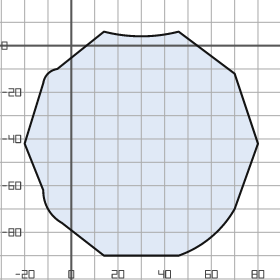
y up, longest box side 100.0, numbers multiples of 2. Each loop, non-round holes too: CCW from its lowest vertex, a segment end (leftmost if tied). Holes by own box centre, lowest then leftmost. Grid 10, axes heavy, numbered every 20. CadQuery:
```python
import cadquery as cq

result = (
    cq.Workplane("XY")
    .moveTo(14.0, -90.0)
    .lineTo(46.0, -90.0)
    .threePointArc((60.0, -82.0), (70.0, -70.0))
    .lineTo(80.0, -42.0)
    .lineTo(70.0, -12.0)
    .lineTo(46.0, 6.0)
    .threePointArc((30.0, 4.0), (14.0, 6.0))
    .lineTo(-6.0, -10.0)
    .threePointArc((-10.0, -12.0), (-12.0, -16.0))
    .lineTo(-20.0, -42.0)
    .lineTo(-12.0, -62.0)
    .threePointArc((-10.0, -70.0), (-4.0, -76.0))
    .close()
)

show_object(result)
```